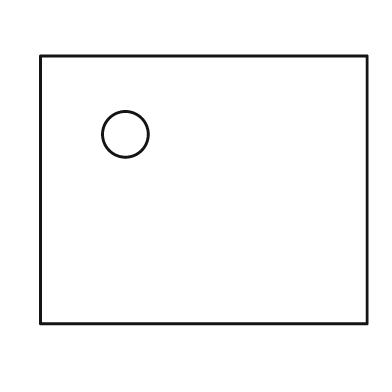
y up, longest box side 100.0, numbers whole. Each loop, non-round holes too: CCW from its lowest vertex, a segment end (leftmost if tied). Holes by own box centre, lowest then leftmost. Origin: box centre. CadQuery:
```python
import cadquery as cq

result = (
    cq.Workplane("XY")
    .moveTo(-50.0, -41.0)
    .lineTo(50.0, -41.0)
    .lineTo(50.0, 41.0)
    .lineTo(-50.0, 41.0)
    .close()
    .moveTo(-24.0, 17.0)
    .circle(7.0)
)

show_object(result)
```